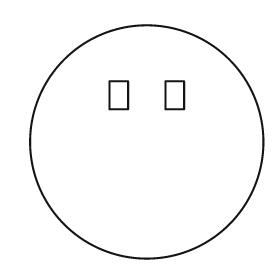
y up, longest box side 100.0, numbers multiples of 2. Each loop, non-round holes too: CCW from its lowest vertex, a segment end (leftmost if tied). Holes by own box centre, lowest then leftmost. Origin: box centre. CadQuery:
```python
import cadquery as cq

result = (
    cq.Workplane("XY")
    .moveTo(0.0, 0.0)
    .circle(50.0)
    .moveTo(-16.0, 14.0)
    .lineTo(-8.0, 14.0)
    .lineTo(-8.0, 26.0)
    .lineTo(-16.0, 26.0)
    .close()
    .moveTo(8.0, 14.0)
    .lineTo(16.0, 14.0)
    .lineTo(16.0, 26.0)
    .lineTo(8.0, 26.0)
    .close()
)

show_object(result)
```